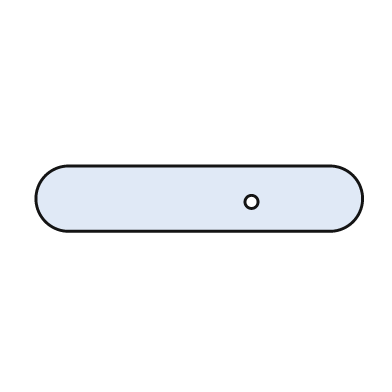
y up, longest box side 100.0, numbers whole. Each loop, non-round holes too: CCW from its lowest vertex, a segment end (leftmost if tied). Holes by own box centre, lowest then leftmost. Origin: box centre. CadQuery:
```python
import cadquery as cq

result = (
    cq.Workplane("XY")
    .moveTo(-40.0, -10.0)
    .lineTo(40.0, -10.0)
    .threePointArc((50.0, 0.0), (40.0, 10.0))
    .lineTo(-40.0, 10.0)
    .threePointArc((-50.0, 0.0), (-40.0, -10.0))
    .close()
    .moveTo(16.0, -1.0)
    .circle(2.0)
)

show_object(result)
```